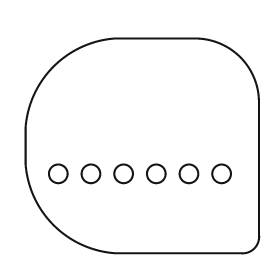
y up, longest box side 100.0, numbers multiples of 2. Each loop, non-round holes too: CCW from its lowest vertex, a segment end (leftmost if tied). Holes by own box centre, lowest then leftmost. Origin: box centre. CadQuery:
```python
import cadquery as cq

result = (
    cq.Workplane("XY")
    .moveTo(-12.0, -46.0)
    .lineTo(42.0, -46.0)
    .threePointArc((48.0, -44.0), (50.0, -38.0))
    .lineTo(50.0, 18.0)
    .threePointArc((42.0, 38.0), (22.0, 46.0))
    .lineTo(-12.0, 46.0)
    .threePointArc((-38.0, 34.0), (-50.0, 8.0))
    .lineTo(-50.0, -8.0)
    .threePointArc((-38.0, -34.0), (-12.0, -46.0))
    .close()
    .moveTo(-36.0, -12.0)
    .circle(4.0)
    .moveTo(-22.0, -12.0)
    .circle(4.0)
    .moveTo(-8.0, -12.0)
    .circle(4.0)
    .moveTo(6.0, -12.0)
    .circle(4.0)
    .moveTo(20.0, -12.0)
    .circle(4.0)
    .moveTo(34.0, -12.0)
    .circle(4.0)
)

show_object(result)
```